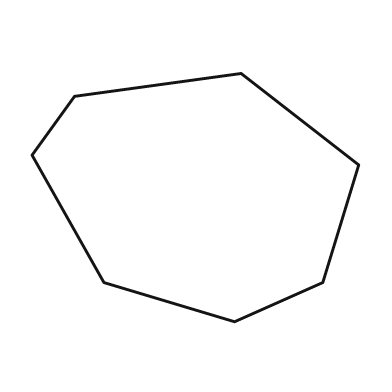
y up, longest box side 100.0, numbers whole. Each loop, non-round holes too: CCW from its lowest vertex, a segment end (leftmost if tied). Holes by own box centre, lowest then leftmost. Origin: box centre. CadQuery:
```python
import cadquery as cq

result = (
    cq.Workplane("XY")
    .moveTo(12.0, -38.0)
    .lineTo(39.0, -26.0)
    .lineTo(50.0, 10.0)
    .lineTo(14.0, 38.0)
    .lineTo(-37.0, 31.0)
    .lineTo(-50.0, 13.0)
    .lineTo(-28.0, -26.0)
    .close()
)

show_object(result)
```